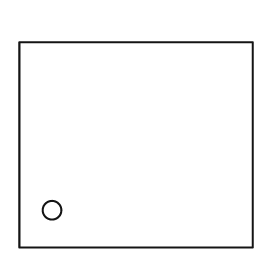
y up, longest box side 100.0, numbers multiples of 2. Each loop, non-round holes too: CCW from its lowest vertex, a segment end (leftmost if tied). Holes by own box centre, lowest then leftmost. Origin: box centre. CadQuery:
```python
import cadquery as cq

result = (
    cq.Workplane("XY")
    .moveTo(-50.0, -44.0)
    .lineTo(50.0, -44.0)
    .lineTo(50.0, 44.0)
    .lineTo(-50.0, 44.0)
    .close()
    .moveTo(-36.0, -28.0)
    .circle(4.0)
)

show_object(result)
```